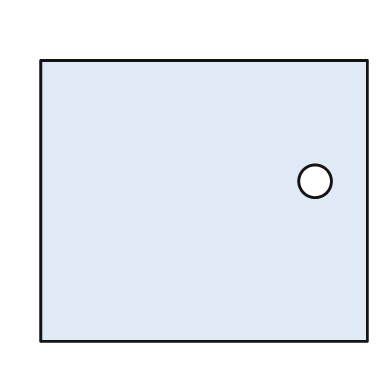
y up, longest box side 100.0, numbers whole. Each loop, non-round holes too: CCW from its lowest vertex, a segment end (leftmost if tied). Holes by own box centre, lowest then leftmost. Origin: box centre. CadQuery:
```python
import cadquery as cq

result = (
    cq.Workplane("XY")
    .moveTo(-50.0, -43.0)
    .lineTo(50.0, -43.0)
    .lineTo(50.0, 43.0)
    .lineTo(-50.0, 43.0)
    .close()
    .moveTo(34.0, 6.0)
    .circle(5.0)
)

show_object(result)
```